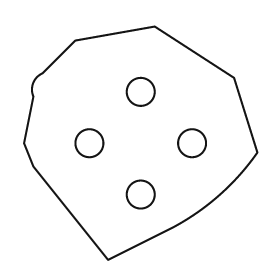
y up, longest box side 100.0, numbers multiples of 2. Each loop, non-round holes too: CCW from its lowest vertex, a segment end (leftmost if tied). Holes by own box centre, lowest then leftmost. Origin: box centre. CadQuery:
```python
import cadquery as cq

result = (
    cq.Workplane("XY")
    .moveTo(-14.0, -50.0)
    .lineTo(14.0, -36.0)
    .threePointArc((34.0, -22.0), (50.0, -4.0))
    .lineTo(40.0, 28.0)
    .lineTo(6.0, 50.0)
    .lineTo(-28.0, 44.0)
    .lineTo(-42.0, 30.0)
    .threePointArc((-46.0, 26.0), (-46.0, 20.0))
    .lineTo(-50.0, 0.0)
    .lineTo(-46.0, -10.0)
    .close()
    .moveTo(0.0, -22.0)
    .circle(6.0)
    .moveTo(-22.0, 0.0)
    .circle(6.0)
    .moveTo(22.0, 0.0)
    .circle(6.0)
    .moveTo(0.0, 22.0)
    .circle(6.0)
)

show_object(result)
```